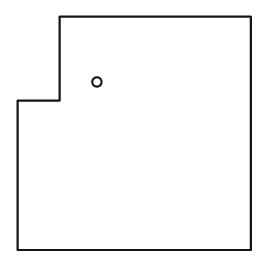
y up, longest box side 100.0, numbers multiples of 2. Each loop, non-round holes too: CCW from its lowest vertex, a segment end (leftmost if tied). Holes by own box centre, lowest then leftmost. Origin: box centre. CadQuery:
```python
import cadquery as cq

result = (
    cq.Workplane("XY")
    .moveTo(-50.0, -50.0)
    .lineTo(50.0, -50.0)
    .lineTo(50.0, 50.0)
    .lineTo(-32.0, 50.0)
    .lineTo(-32.0, 14.0)
    .lineTo(-50.0, 14.0)
    .close()
    .moveTo(-16.0, 22.0)
    .circle(2.0)
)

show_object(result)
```